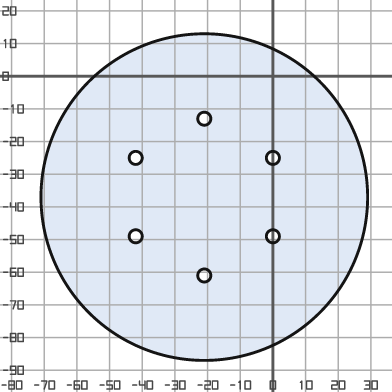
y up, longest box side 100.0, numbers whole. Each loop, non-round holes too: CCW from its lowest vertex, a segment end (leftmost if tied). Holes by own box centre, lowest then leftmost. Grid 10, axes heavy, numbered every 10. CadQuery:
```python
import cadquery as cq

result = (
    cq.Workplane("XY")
    .moveTo(-21.0, -37.0)
    .circle(50.0)
    .moveTo(-21.0, -61.0)
    .circle(2.0)
    .moveTo(-42.0, -49.0)
    .circle(2.0)
    .moveTo(0.0, -49.0)
    .circle(2.0)
    .moveTo(-42.0, -25.0)
    .circle(2.0)
    .moveTo(0.0, -25.0)
    .circle(2.0)
    .moveTo(-21.0, -13.0)
    .circle(2.0)
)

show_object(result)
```